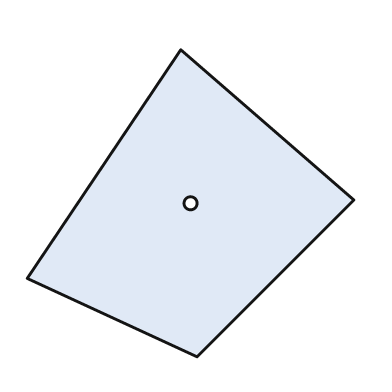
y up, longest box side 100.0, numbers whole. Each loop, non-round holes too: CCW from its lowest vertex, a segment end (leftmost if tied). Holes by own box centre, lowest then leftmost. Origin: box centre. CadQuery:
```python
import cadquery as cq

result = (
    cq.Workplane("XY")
    .moveTo(2.0, -47.0)
    .lineTo(50.0, 1.0)
    .lineTo(-3.0, 47.0)
    .lineTo(-50.0, -23.0)
    .close()
    .moveTo(0.0, 0.0)
    .circle(2.0)
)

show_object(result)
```